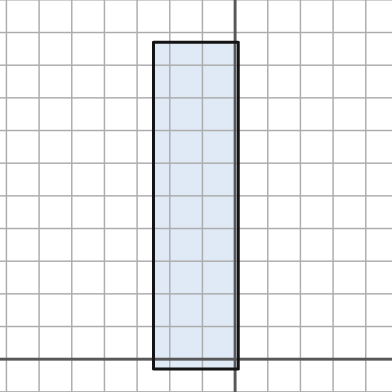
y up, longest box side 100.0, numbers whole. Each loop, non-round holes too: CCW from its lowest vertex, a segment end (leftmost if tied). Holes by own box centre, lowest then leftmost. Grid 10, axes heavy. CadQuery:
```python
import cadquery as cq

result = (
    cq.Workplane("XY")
    .moveTo(-25.0, -3.0)
    .lineTo(1.0, -3.0)
    .lineTo(1.0, 97.0)
    .lineTo(-25.0, 97.0)
    .close()
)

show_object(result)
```